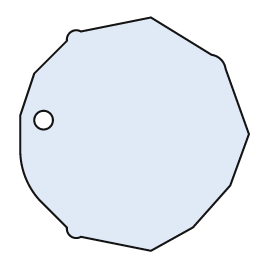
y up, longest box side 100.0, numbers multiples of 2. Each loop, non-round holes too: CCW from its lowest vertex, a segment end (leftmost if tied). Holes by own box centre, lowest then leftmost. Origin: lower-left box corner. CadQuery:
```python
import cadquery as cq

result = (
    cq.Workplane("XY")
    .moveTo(56.0, 0.0)
    .lineTo(74.0, 10.0)
    .lineTo(90.0, 28.0)
    .lineTo(98.0, 50.0)
    .lineTo(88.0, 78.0)
    .threePointArc((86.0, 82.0), (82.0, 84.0))
    .lineTo(56.0, 100.0)
    .lineTo(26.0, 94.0)
    .threePointArc((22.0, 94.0), (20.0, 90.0))
    .lineTo(6.0, 76.0)
    .lineTo(0.0, 58.0)
    .lineTo(0.0, 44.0)
    .threePointArc((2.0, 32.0), (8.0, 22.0))
    .lineTo(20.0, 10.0)
    .threePointArc((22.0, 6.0), (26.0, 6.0))
    .close()
    .moveTo(10.0, 56.0)
    .circle(4.0)
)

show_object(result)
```